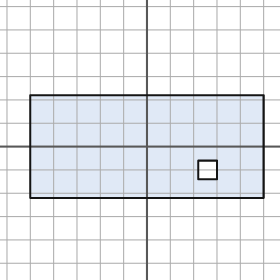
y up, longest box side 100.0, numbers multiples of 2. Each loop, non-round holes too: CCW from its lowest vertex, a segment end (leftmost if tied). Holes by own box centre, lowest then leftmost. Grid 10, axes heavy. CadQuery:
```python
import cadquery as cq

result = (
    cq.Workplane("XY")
    .moveTo(-50.0, -22.0)
    .lineTo(50.0, -22.0)
    .lineTo(50.0, 22.0)
    .lineTo(-50.0, 22.0)
    .close()
    .moveTo(22.0, -14.0)
    .lineTo(30.0, -14.0)
    .lineTo(30.0, -6.0)
    .lineTo(22.0, -6.0)
    .close()
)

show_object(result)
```